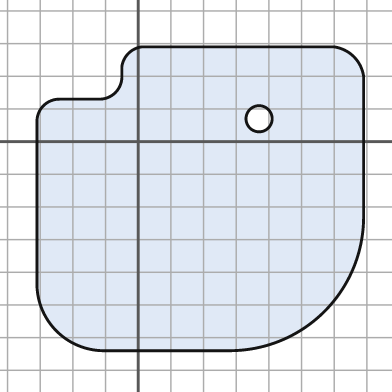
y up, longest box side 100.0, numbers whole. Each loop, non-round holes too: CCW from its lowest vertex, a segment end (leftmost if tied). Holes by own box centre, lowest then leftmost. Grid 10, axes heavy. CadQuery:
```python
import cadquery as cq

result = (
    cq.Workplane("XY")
    .moveTo(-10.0, -64.0)
    .lineTo(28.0, -64.0)
    .threePointArc((57.0, -52.0), (69.0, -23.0))
    .lineTo(69.0, 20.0)
    .threePointArc((66.0, 26.0), (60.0, 29.0))
    .lineTo(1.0, 29.0)
    .threePointArc((-3.0, 27.0), (-5.0, 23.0))
    .lineTo(-5.0, 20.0)
    .threePointArc((-7.0, 15.0), (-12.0, 13.0))
    .lineTo(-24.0, 13.0)
    .threePointArc((-29.0, 11.0), (-31.0, 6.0))
    .lineTo(-31.0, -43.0)
    .threePointArc((-25.0, -58.0), (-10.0, -64.0))
    .close()
    .moveTo(37.0, 7.0)
    .circle(4.0)
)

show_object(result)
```